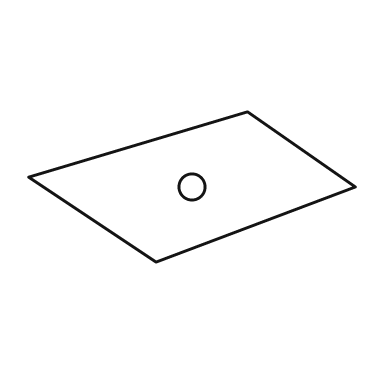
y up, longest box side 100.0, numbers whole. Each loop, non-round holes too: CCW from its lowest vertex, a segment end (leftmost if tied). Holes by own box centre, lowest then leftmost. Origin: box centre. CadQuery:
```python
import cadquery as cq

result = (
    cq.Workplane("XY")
    .moveTo(-11.0, -23.0)
    .lineTo(50.0, 0.0)
    .lineTo(17.0, 23.0)
    .lineTo(-50.0, 3.0)
    .close()
    .moveTo(0.0, 0.0)
    .circle(4.0)
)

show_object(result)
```